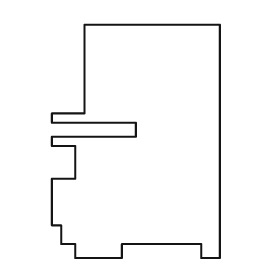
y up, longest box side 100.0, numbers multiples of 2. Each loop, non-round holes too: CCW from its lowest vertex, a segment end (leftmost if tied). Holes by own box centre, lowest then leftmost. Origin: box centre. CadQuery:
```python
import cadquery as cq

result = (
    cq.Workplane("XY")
    .moveTo(-26.0, -50.0)
    .lineTo(-6.0, -50.0)
    .lineTo(-6.0, -44.0)
    .lineTo(28.0, -44.0)
    .lineTo(28.0, -50.0)
    .lineTo(36.0, -50.0)
    .lineTo(36.0, 50.0)
    .lineTo(-22.0, 50.0)
    .lineTo(-22.0, 12.0)
    .lineTo(-36.0, 12.0)
    .lineTo(-36.0, 8.0)
    .lineTo(0.0, 8.0)
    .lineTo(0.0, 2.0)
    .lineTo(-36.0, 2.0)
    .lineTo(-36.0, -2.0)
    .lineTo(-26.0, -2.0)
    .lineTo(-26.0, -16.0)
    .lineTo(-36.0, -16.0)
    .lineTo(-36.0, -36.0)
    .lineTo(-32.0, -36.0)
    .lineTo(-32.0, -44.0)
    .lineTo(-26.0, -44.0)
    .close()
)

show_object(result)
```